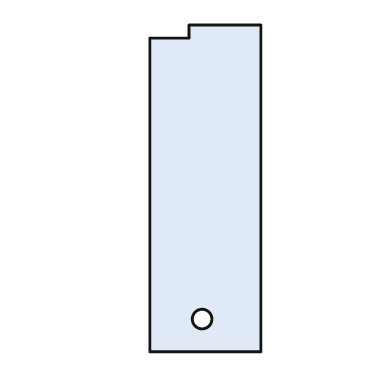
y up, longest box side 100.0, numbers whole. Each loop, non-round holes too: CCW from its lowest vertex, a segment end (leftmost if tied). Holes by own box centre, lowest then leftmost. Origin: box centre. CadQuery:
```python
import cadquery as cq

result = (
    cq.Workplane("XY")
    .moveTo(-17.0, -50.0)
    .lineTo(17.0, -50.0)
    .lineTo(17.0, 50.0)
    .lineTo(-5.0, 50.0)
    .lineTo(-5.0, 46.0)
    .lineTo(-17.0, 46.0)
    .close()
    .moveTo(-1.0, -40.0)
    .circle(3.0)
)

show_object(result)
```